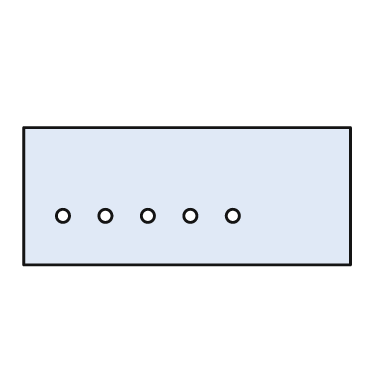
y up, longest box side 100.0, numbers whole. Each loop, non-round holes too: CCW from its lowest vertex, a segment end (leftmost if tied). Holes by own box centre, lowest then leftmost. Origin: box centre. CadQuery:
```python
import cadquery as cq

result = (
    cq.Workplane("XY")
    .moveTo(-50.0, -21.0)
    .lineTo(50.0, -21.0)
    .lineTo(50.0, 21.0)
    .lineTo(-50.0, 21.0)
    .close()
    .moveTo(-38.0, -6.0)
    .circle(2.0)
    .moveTo(-25.0, -6.0)
    .circle(2.0)
    .moveTo(-12.0, -6.0)
    .circle(2.0)
    .moveTo(1.0, -6.0)
    .circle(2.0)
    .moveTo(14.0, -6.0)
    .circle(2.0)
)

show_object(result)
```